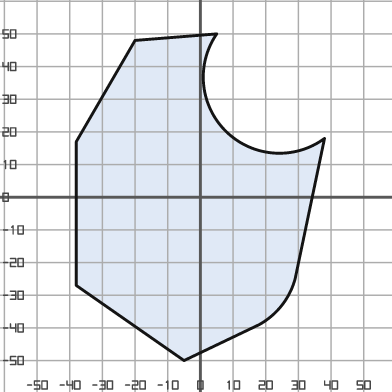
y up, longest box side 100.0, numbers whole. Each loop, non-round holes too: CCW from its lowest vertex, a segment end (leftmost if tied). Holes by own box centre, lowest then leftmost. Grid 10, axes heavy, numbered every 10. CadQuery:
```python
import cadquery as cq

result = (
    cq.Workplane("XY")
    .moveTo(-5.0, -50.0)
    .lineTo(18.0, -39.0)
    .threePointArc((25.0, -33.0), (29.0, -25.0))
    .lineTo(38.0, 18.0)
    .threePointArc((8.0, 20.0), (5.0, 50.0))
    .lineTo(-20.0, 48.0)
    .lineTo(-38.0, 17.0)
    .lineTo(-38.0, -27.0)
    .close()
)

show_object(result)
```